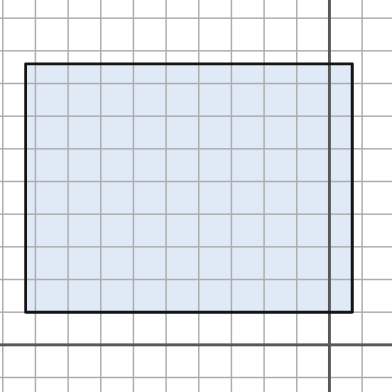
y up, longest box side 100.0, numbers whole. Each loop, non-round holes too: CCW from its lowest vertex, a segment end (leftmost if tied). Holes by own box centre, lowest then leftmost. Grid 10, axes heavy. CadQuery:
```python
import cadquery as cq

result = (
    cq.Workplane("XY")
    .moveTo(-93.0, 10.0)
    .lineTo(7.0, 10.0)
    .lineTo(7.0, 86.0)
    .lineTo(-93.0, 86.0)
    .close()
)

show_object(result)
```